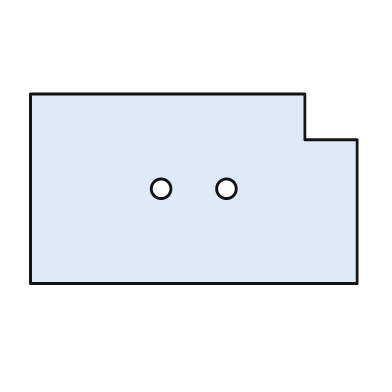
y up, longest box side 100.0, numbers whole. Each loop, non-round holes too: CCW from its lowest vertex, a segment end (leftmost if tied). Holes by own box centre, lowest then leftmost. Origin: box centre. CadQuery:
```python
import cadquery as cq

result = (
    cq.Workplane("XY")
    .moveTo(-50.0, -29.0)
    .lineTo(50.0, -29.0)
    .lineTo(50.0, 15.0)
    .lineTo(34.0, 15.0)
    .lineTo(34.0, 29.0)
    .lineTo(-50.0, 29.0)
    .close()
    .moveTo(-10.0, 0.0)
    .circle(3.0)
    .moveTo(10.0, 0.0)
    .circle(3.0)
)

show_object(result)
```